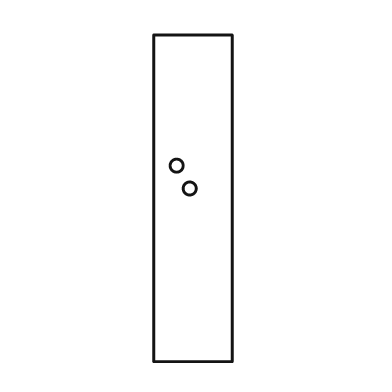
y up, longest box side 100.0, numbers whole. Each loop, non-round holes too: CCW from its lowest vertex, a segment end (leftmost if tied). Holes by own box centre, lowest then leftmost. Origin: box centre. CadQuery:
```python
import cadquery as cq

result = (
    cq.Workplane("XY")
    .moveTo(-12.0, -50.0)
    .lineTo(12.0, -50.0)
    .lineTo(12.0, 50.0)
    .lineTo(-12.0, 50.0)
    .close()
    .moveTo(-1.0, 3.0)
    .circle(2.0)
    .moveTo(-5.0, 10.0)
    .circle(2.0)
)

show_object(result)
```